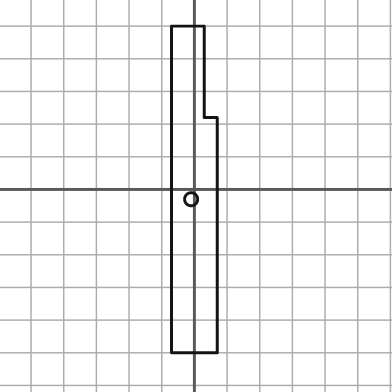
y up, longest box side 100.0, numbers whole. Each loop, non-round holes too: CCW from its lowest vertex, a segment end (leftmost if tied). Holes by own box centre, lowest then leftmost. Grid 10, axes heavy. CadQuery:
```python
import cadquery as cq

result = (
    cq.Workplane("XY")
    .moveTo(-7.0, -50.0)
    .lineTo(7.0, -50.0)
    .lineTo(7.0, 22.0)
    .lineTo(3.0, 22.0)
    .lineTo(3.0, 50.0)
    .lineTo(-7.0, 50.0)
    .close()
    .moveTo(-1.0, -3.0)
    .circle(2.0)
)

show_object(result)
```